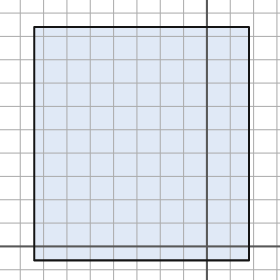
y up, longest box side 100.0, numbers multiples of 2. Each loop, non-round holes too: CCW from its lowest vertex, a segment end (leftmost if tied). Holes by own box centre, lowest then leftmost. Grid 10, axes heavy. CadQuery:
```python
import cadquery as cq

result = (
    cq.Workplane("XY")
    .moveTo(-74.0, -6.0)
    .lineTo(18.0, -6.0)
    .lineTo(18.0, 94.0)
    .lineTo(-74.0, 94.0)
    .close()
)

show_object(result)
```